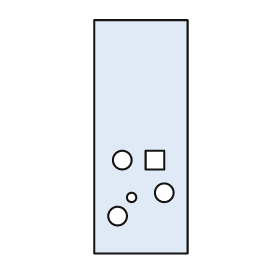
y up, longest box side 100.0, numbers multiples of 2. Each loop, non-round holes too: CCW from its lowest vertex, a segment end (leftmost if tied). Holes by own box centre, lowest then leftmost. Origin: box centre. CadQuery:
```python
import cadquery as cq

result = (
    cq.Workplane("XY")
    .moveTo(-20.0, -50.0)
    .lineTo(20.0, -50.0)
    .lineTo(20.0, 50.0)
    .lineTo(-20.0, 50.0)
    .close()
    .moveTo(-10.0, -34.0)
    .circle(4.0)
    .moveTo(-4.0, -26.0)
    .circle(2.0)
    .moveTo(10.0, -24.0)
    .circle(4.0)
    .moveTo(-8.0, -10.0)
    .circle(4.0)
    .moveTo(2.0, -14.0)
    .lineTo(10.0, -14.0)
    .lineTo(10.0, -6.0)
    .lineTo(2.0, -6.0)
    .close()
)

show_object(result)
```